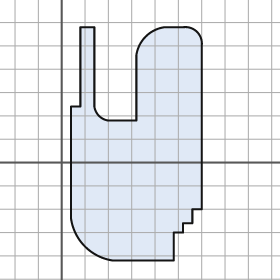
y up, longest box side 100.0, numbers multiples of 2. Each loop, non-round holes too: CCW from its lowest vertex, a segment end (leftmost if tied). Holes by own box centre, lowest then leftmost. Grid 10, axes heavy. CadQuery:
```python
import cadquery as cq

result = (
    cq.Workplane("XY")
    .moveTo(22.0, -42.0)
    .lineTo(48.0, -42.0)
    .lineTo(48.0, -30.0)
    .lineTo(52.0, -30.0)
    .lineTo(52.0, -26.0)
    .lineTo(56.0, -26.0)
    .lineTo(56.0, -20.0)
    .lineTo(60.0, -20.0)
    .lineTo(60.0, 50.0)
    .threePointArc((58.0, 56.0), (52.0, 58.0))
    .lineTo(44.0, 58.0)
    .threePointArc((36.0, 54.0), (32.0, 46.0))
    .lineTo(32.0, 18.0)
    .lineTo(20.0, 18.0)
    .threePointArc((16.0, 20.0), (14.0, 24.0))
    .lineTo(14.0, 58.0)
    .lineTo(8.0, 58.0)
    .lineTo(8.0, 24.0)
    .lineTo(4.0, 24.0)
    .lineTo(4.0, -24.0)
    .threePointArc((10.0, -36.0), (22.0, -42.0))
    .close()
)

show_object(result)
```